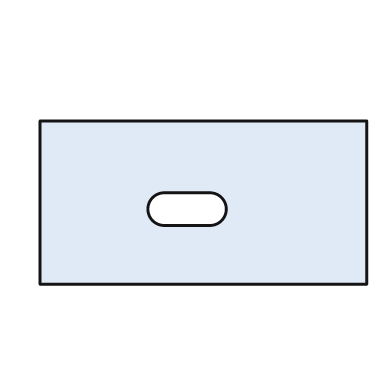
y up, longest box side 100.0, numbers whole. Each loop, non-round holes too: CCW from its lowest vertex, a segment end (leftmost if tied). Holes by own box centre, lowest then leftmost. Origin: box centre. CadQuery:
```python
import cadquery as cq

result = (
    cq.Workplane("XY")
    .moveTo(-50.0, -25.0)
    .lineTo(50.0, -25.0)
    .lineTo(50.0, 25.0)
    .lineTo(-50.0, 25.0)
    .close()
    .moveTo(-12.0, -7.0)
    .lineTo(2.0, -7.0)
    .threePointArc((7.0, -2.0), (2.0, 3.0))
    .lineTo(-12.0, 3.0)
    .threePointArc((-17.0, -2.0), (-12.0, -7.0))
    .close()
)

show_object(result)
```